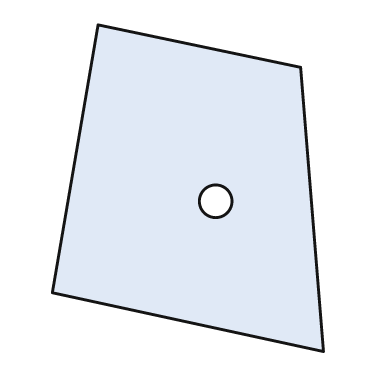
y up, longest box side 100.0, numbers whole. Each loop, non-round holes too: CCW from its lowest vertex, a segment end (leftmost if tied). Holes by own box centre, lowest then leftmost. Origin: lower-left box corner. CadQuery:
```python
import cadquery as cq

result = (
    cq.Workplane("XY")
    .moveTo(83.0, 0.0)
    .lineTo(76.0, 87.0)
    .lineTo(14.0, 100.0)
    .lineTo(0.0, 18.0)
    .close()
    .moveTo(50.0, 46.0)
    .circle(5.0)
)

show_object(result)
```